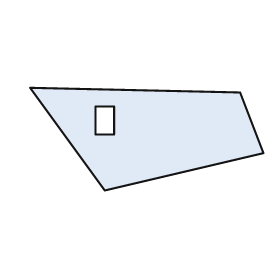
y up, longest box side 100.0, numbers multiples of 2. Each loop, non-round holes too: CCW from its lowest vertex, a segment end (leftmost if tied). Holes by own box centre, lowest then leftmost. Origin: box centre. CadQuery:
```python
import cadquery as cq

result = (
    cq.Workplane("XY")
    .moveTo(-18.0, -22.0)
    .lineTo(50.0, -6.0)
    .lineTo(40.0, 20.0)
    .lineTo(-50.0, 22.0)
    .close()
    .moveTo(-22.0, 2.0)
    .lineTo(-14.0, 2.0)
    .lineTo(-14.0, 14.0)
    .lineTo(-22.0, 14.0)
    .close()
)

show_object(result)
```